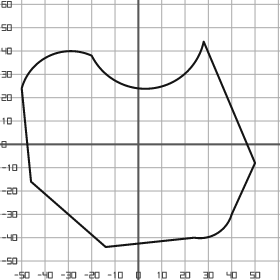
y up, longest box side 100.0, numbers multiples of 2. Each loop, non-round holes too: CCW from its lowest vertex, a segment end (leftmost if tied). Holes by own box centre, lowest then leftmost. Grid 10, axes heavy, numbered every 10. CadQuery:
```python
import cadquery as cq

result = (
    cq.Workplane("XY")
    .moveTo(-14.0, -44.0)
    .lineTo(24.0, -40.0)
    .threePointArc((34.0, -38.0), (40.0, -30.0))
    .lineTo(50.0, -8.0)
    .lineTo(28.0, 44.0)
    .threePointArc((6.0, 24.0), (-20.0, 38.0))
    .threePointArc((-38.0, 38.0), (-50.0, 24.0))
    .lineTo(-46.0, -16.0)
    .close()
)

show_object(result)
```